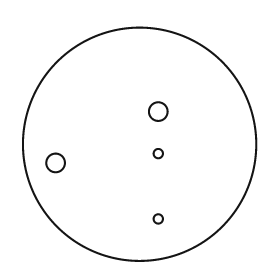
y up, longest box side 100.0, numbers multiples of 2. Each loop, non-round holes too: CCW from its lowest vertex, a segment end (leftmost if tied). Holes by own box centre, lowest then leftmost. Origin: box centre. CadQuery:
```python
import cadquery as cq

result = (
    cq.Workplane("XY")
    .moveTo(0.0, 0.0)
    .circle(50.0)
    .moveTo(8.0, -32.0)
    .circle(2.0)
    .moveTo(-36.0, -8.0)
    .circle(4.0)
    .moveTo(8.0, -4.0)
    .circle(2.0)
    .moveTo(8.0, 14.0)
    .circle(4.0)
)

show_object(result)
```